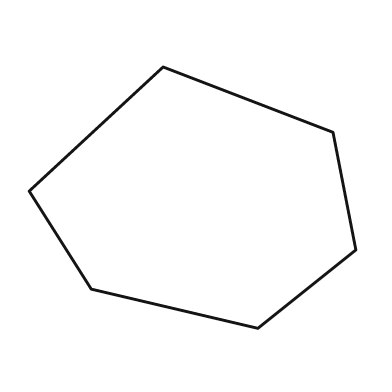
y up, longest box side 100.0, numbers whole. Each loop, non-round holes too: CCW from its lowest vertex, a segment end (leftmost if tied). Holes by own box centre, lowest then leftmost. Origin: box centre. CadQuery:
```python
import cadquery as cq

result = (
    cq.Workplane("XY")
    .moveTo(20.0, -40.0)
    .lineTo(50.0, -16.0)
    .lineTo(43.0, 20.0)
    .lineTo(-9.0, 40.0)
    .lineTo(-50.0, 2.0)
    .lineTo(-31.0, -28.0)
    .close()
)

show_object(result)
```